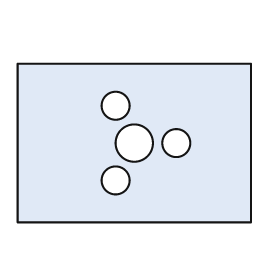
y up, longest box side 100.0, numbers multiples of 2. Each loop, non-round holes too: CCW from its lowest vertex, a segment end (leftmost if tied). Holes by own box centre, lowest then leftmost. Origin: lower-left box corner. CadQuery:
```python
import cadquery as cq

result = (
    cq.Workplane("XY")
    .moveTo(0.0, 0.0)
    .lineTo(100.0, 0.0)
    .lineTo(100.0, 68.0)
    .lineTo(0.0, 68.0)
    .close()
    .moveTo(42.0, 18.0)
    .circle(6.0)
    .moveTo(50.0, 34.0)
    .circle(8.0)
    .moveTo(68.0, 34.0)
    .circle(6.0)
    .moveTo(42.0, 50.0)
    .circle(6.0)
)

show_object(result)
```